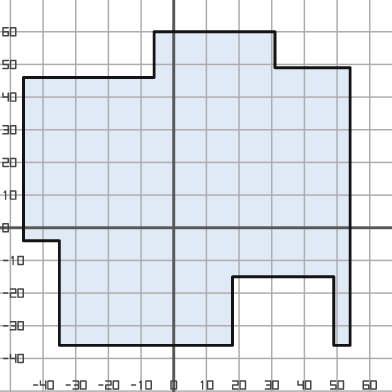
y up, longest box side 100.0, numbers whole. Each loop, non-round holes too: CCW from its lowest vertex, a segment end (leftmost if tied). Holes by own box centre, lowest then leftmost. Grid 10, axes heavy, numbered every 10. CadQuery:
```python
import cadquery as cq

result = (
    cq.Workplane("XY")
    .moveTo(-35.0, -36.0)
    .lineTo(18.0, -36.0)
    .lineTo(18.0, -15.0)
    .lineTo(49.0, -15.0)
    .lineTo(49.0, -36.0)
    .lineTo(54.0, -36.0)
    .lineTo(54.0, 49.0)
    .lineTo(31.0, 49.0)
    .lineTo(31.0, 60.0)
    .lineTo(-6.0, 60.0)
    .lineTo(-6.0, 46.0)
    .lineTo(-46.0, 46.0)
    .lineTo(-46.0, -4.0)
    .lineTo(-35.0, -4.0)
    .close()
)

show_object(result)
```